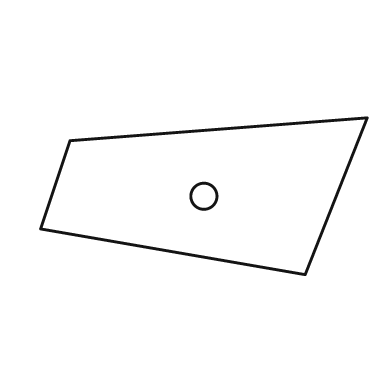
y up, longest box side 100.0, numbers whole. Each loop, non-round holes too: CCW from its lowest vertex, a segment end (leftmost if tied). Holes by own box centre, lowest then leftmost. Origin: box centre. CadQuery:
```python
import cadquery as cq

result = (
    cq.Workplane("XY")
    .moveTo(31.0, -24.0)
    .lineTo(50.0, 24.0)
    .lineTo(-41.0, 17.0)
    .lineTo(-50.0, -10.0)
    .close()
    .moveTo(0.0, 0.0)
    .circle(4.0)
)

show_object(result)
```